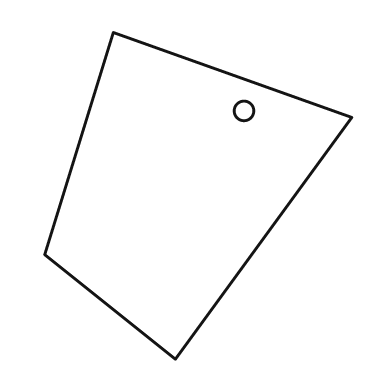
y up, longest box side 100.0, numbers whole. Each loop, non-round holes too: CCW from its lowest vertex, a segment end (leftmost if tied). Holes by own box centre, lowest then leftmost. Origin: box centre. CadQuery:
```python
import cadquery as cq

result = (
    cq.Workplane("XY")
    .moveTo(-7.0, -50.0)
    .lineTo(47.0, 24.0)
    .lineTo(-26.0, 50.0)
    .lineTo(-47.0, -18.0)
    .close()
    .moveTo(14.0, 26.0)
    .circle(3.0)
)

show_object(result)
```